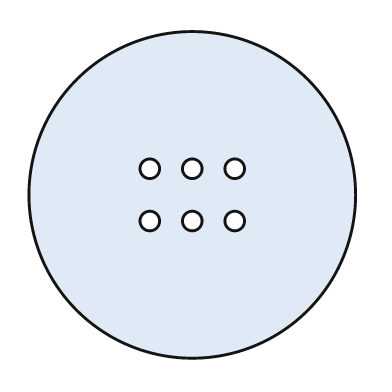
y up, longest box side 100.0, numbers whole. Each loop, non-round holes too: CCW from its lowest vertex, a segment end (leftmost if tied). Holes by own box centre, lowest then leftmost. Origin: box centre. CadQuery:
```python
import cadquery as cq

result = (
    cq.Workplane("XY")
    .moveTo(0.0, 0.0)
    .circle(50.0)
    .moveTo(-13.0, -8.0)
    .circle(3.0)
    .moveTo(0.0, -8.0)
    .circle(3.0)
    .moveTo(13.0, -8.0)
    .circle(3.0)
    .moveTo(-13.0, 8.0)
    .circle(3.0)
    .moveTo(0.0, 8.0)
    .circle(3.0)
    .moveTo(13.0, 8.0)
    .circle(3.0)
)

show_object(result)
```